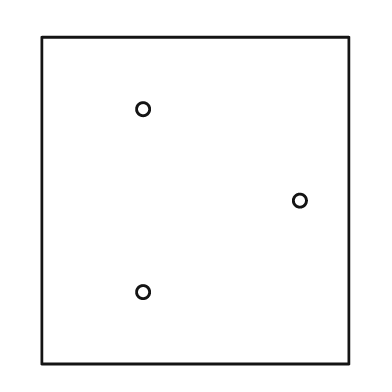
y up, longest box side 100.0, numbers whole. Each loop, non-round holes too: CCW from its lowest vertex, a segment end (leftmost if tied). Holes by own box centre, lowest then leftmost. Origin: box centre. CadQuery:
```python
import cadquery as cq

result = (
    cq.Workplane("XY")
    .moveTo(-47.0, -50.0)
    .lineTo(47.0, -50.0)
    .lineTo(47.0, 50.0)
    .lineTo(-47.0, 50.0)
    .close()
    .moveTo(-16.0, -28.0)
    .circle(2.0)
    .moveTo(32.0, 0.0)
    .circle(2.0)
    .moveTo(-16.0, 28.0)
    .circle(2.0)
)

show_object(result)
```